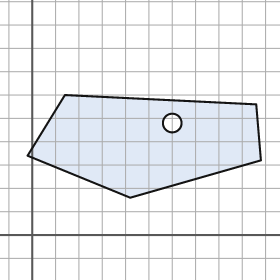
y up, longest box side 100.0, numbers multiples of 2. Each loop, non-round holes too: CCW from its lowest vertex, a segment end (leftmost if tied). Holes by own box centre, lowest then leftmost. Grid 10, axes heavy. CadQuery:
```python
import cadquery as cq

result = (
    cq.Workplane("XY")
    .moveTo(42.0, 16.0)
    .lineTo(98.0, 32.0)
    .lineTo(96.0, 56.0)
    .lineTo(14.0, 60.0)
    .lineTo(-2.0, 34.0)
    .close()
    .moveTo(60.0, 48.0)
    .circle(4.0)
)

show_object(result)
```